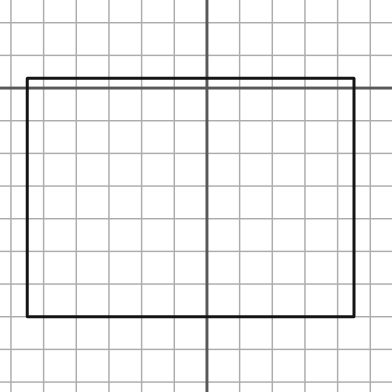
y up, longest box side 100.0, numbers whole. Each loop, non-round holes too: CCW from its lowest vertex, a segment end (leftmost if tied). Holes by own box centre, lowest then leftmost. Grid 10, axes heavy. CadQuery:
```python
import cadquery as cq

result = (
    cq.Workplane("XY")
    .moveTo(-55.0, -70.0)
    .lineTo(45.0, -70.0)
    .lineTo(45.0, 3.0)
    .lineTo(-55.0, 3.0)
    .close()
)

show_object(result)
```